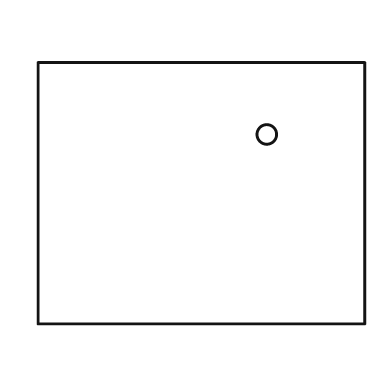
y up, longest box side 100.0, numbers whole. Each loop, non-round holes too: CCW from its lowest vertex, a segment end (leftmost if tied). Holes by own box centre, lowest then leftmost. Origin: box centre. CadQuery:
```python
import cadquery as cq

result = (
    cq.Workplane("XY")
    .moveTo(-50.0, -40.0)
    .lineTo(50.0, -40.0)
    .lineTo(50.0, 40.0)
    .lineTo(-50.0, 40.0)
    .close()
    .moveTo(20.0, 18.0)
    .circle(3.0)
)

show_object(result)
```